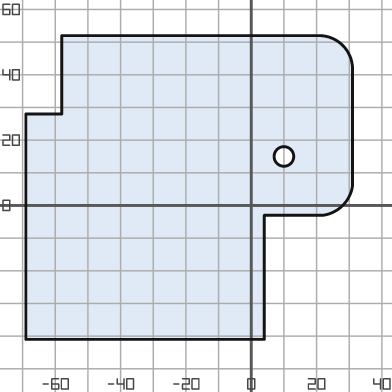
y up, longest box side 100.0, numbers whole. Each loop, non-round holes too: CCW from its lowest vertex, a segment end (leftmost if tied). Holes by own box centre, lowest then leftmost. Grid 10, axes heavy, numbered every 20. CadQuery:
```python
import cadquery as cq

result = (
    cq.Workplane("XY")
    .moveTo(-69.0, -41.0)
    .lineTo(4.0, -41.0)
    .lineTo(4.0, -3.0)
    .lineTo(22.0, -3.0)
    .threePointArc((28.0, 0.0), (31.0, 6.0))
    .lineTo(31.0, 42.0)
    .threePointArc((28.0, 49.0), (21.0, 52.0))
    .lineTo(-58.0, 52.0)
    .lineTo(-58.0, 28.0)
    .lineTo(-69.0, 28.0)
    .close()
    .moveTo(10.0, 15.0)
    .circle(3.0)
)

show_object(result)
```